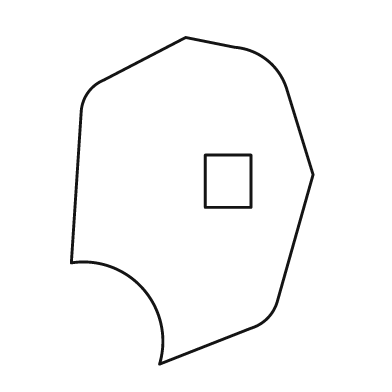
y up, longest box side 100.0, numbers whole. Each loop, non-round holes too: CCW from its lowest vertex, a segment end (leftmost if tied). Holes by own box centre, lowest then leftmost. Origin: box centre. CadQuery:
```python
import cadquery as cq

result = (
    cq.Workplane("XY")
    .moveTo(-10.0, -50.0)
    .lineTo(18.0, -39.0)
    .threePointArc((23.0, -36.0), (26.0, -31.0))
    .lineTo(37.0, 8.0)
    .lineTo(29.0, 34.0)
    .threePointArc((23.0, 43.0), (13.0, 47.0))
    .lineTo(-2.0, 50.0)
    .lineTo(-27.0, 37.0)
    .threePointArc((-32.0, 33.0), (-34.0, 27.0))
    .lineTo(-37.0, -19.0)
    .threePointArc((-15.0, -27.0), (-10.0, -50.0))
    .close()
    .moveTo(4.0, -2.0)
    .lineTo(18.0, -2.0)
    .lineTo(18.0, 14.0)
    .lineTo(4.0, 14.0)
    .close()
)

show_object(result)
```